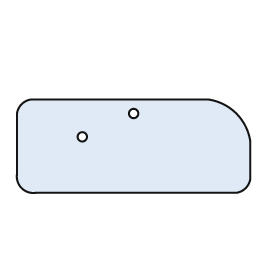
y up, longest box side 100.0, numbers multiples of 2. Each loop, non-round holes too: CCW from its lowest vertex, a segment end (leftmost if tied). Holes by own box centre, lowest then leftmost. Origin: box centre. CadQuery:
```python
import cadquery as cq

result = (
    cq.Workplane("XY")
    .moveTo(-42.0, -20.0)
    .lineTo(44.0, -20.0)
    .threePointArc((48.0, -18.0), (50.0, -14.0))
    .lineTo(50.0, 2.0)
    .threePointArc((44.0, 14.0), (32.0, 20.0))
    .lineTo(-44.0, 20.0)
    .threePointArc((-48.0, 18.0), (-50.0, 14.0))
    .lineTo(-50.0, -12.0)
    .threePointArc((-48.0, -18.0), (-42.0, -20.0))
    .close()
    .moveTo(-22.0, 4.0)
    .circle(2.0)
    .moveTo(0.0, 14.0)
    .circle(2.0)
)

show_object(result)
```